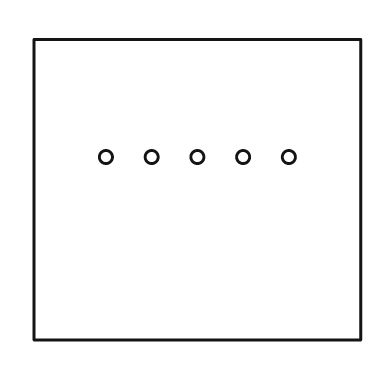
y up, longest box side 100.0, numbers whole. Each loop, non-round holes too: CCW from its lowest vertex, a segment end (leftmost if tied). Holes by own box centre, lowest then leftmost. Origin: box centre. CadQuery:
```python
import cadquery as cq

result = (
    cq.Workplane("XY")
    .moveTo(-50.0, -46.0)
    .lineTo(50.0, -46.0)
    .lineTo(50.0, 46.0)
    .lineTo(-50.0, 46.0)
    .close()
    .moveTo(-28.0, 10.0)
    .circle(2.0)
    .moveTo(-14.0, 10.0)
    .circle(2.0)
    .moveTo(0.0, 10.0)
    .circle(2.0)
    .moveTo(14.0, 10.0)
    .circle(2.0)
    .moveTo(28.0, 10.0)
    .circle(2.0)
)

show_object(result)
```